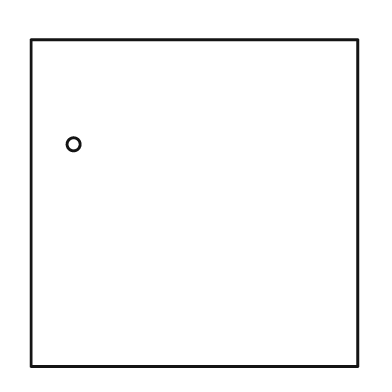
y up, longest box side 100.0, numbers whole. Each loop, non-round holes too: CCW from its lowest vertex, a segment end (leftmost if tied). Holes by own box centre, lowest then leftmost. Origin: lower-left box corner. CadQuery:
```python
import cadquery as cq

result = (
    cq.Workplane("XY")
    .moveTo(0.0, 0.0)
    .lineTo(100.0, 0.0)
    .lineTo(100.0, 100.0)
    .lineTo(0.0, 100.0)
    .close()
    .moveTo(13.0, 68.0)
    .circle(2.0)
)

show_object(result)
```